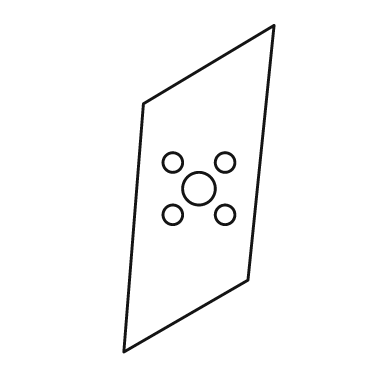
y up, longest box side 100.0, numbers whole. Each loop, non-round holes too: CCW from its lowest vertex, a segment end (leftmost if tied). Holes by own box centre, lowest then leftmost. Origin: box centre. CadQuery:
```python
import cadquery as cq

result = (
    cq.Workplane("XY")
    .moveTo(-23.0, -50.0)
    .lineTo(15.0, -28.0)
    .lineTo(23.0, 50.0)
    .lineTo(-17.0, 26.0)
    .close()
    .moveTo(-8.0, -8.0)
    .circle(3.0)
    .moveTo(8.0, -8.0)
    .circle(3.0)
    .moveTo(0.0, 0.0)
    .circle(5.0)
    .moveTo(-8.0, 8.0)
    .circle(3.0)
    .moveTo(8.0, 8.0)
    .circle(3.0)
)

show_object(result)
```